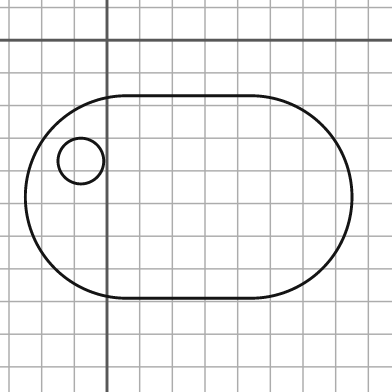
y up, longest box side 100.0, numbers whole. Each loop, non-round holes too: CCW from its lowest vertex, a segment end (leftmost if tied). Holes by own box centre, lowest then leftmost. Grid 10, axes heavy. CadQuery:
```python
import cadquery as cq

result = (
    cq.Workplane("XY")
    .moveTo(6.0, -79.0)
    .lineTo(44.0, -79.0)
    .threePointArc((75.0, -48.0), (44.0, -17.0))
    .lineTo(6.0, -17.0)
    .threePointArc((-25.0, -48.0), (6.0, -79.0))
    .close()
    .moveTo(-8.0, -37.0)
    .circle(7.0)
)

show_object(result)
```